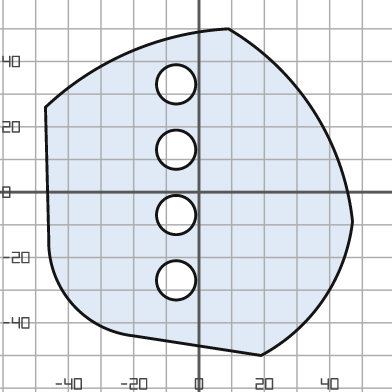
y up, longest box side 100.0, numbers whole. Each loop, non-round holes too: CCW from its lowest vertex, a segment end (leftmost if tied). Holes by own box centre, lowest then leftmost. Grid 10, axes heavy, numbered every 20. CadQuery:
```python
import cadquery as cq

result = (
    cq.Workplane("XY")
    .moveTo(19.0, -50.0)
    .threePointArc((38.0, -33.0), (47.0, -9.0))
    .threePointArc((35.0, 25.0), (9.0, 50.0))
    .threePointArc((-21.0, 43.0), (-47.0, 26.0))
    .lineTo(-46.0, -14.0)
    .threePointArc((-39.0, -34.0), (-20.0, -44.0))
    .close()
    .moveTo(-7.0, -27.0)
    .circle(6.0)
    .moveTo(-7.0, -7.0)
    .circle(6.0)
    .moveTo(-7.0, 13.0)
    .circle(6.0)
    .moveTo(-7.0, 33.0)
    .circle(6.0)
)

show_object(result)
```